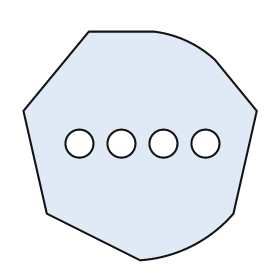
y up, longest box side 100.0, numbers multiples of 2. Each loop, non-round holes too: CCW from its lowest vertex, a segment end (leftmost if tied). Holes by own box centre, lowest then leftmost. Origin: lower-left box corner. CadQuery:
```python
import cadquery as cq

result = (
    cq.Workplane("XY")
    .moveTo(50.0, 0.0)
    .threePointArc((72.0, 6.0), (90.0, 20.0))
    .lineTo(100.0, 64.0)
    .lineTo(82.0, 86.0)
    .threePointArc((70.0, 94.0), (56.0, 98.0))
    .lineTo(28.0, 98.0)
    .lineTo(0.0, 64.0)
    .lineTo(10.0, 20.0)
    .close()
    .moveTo(24.0, 50.0)
    .circle(6.0)
    .moveTo(42.0, 50.0)
    .circle(6.0)
    .moveTo(60.0, 50.0)
    .circle(6.0)
    .moveTo(78.0, 50.0)
    .circle(6.0)
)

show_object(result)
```